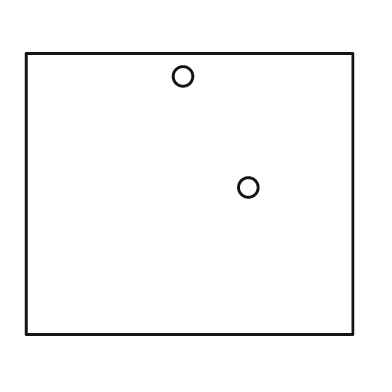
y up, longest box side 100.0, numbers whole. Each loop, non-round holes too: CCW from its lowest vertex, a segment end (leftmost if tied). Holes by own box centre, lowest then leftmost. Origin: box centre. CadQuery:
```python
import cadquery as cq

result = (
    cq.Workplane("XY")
    .moveTo(-50.0, -43.0)
    .lineTo(50.0, -43.0)
    .lineTo(50.0, 43.0)
    .lineTo(-50.0, 43.0)
    .close()
    .moveTo(18.0, 2.0)
    .circle(3.0)
    .moveTo(-2.0, 36.0)
    .circle(3.0)
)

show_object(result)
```